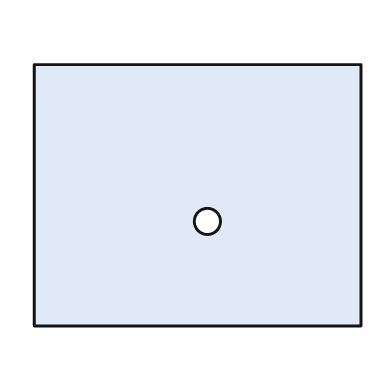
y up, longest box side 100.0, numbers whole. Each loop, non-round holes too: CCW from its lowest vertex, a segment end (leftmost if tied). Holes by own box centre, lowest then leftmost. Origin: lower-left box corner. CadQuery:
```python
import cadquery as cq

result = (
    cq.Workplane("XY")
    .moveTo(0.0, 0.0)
    .lineTo(100.0, 0.0)
    .lineTo(100.0, 80.0)
    .lineTo(0.0, 80.0)
    .close()
    .moveTo(53.0, 32.0)
    .circle(4.0)
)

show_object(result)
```